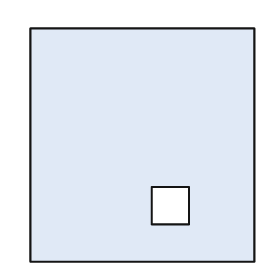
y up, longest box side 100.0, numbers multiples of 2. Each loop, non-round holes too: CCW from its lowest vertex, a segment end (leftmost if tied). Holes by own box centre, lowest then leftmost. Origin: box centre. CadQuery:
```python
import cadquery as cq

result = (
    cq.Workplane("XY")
    .moveTo(-48.0, -50.0)
    .lineTo(48.0, -50.0)
    .lineTo(48.0, 50.0)
    .lineTo(-48.0, 50.0)
    .close()
    .moveTo(4.0, -34.0)
    .lineTo(20.0, -34.0)
    .lineTo(20.0, -18.0)
    .lineTo(4.0, -18.0)
    .close()
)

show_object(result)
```